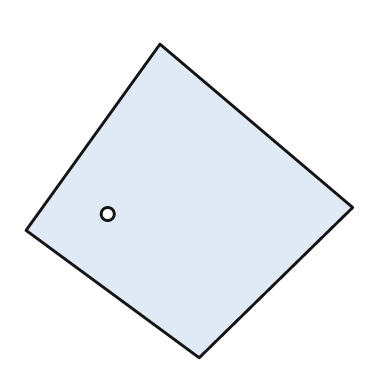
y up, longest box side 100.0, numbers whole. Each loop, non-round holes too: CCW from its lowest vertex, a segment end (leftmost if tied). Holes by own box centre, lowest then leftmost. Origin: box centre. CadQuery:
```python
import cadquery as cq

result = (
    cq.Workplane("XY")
    .moveTo(3.0, -48.0)
    .lineTo(50.0, -2.0)
    .lineTo(-9.0, 48.0)
    .lineTo(-50.0, -9.0)
    .close()
    .moveTo(-25.0, -4.0)
    .circle(2.0)
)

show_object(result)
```